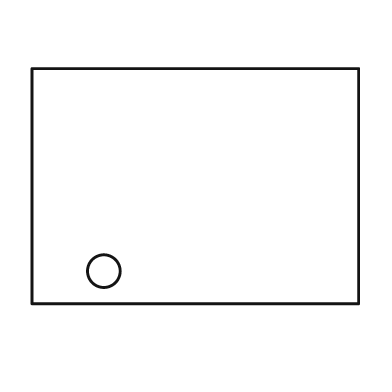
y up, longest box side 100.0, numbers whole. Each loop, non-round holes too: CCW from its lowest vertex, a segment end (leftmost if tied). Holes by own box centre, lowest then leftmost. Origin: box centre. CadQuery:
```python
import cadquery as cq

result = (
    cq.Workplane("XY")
    .moveTo(-50.0, -36.0)
    .lineTo(50.0, -36.0)
    .lineTo(50.0, 36.0)
    .lineTo(-50.0, 36.0)
    .close()
    .moveTo(-28.0, -26.0)
    .circle(5.0)
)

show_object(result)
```